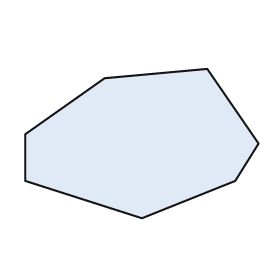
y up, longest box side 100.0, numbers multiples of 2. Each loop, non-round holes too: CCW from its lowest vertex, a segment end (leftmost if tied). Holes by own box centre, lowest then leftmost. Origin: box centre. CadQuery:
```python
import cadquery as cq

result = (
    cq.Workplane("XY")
    .moveTo(0.0, -32.0)
    .lineTo(40.0, -16.0)
    .lineTo(50.0, 0.0)
    .lineTo(28.0, 32.0)
    .lineTo(-16.0, 28.0)
    .lineTo(-50.0, 4.0)
    .lineTo(-50.0, -16.0)
    .close()
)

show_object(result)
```